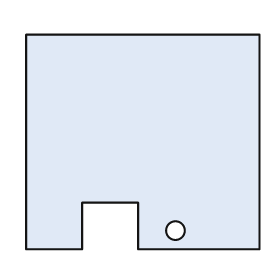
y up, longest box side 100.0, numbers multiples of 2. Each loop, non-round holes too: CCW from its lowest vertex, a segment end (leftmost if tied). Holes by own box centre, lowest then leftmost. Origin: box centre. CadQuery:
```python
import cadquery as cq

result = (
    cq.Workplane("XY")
    .moveTo(-50.0, -46.0)
    .lineTo(-26.0, -46.0)
    .lineTo(-26.0, -26.0)
    .lineTo(-2.0, -26.0)
    .lineTo(-2.0, -46.0)
    .lineTo(50.0, -46.0)
    .lineTo(50.0, 46.0)
    .lineTo(-50.0, 46.0)
    .close()
    .moveTo(14.0, -38.0)
    .circle(4.0)
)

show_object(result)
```